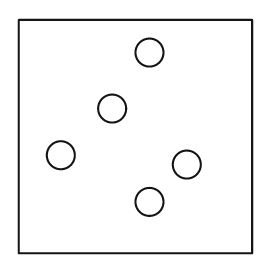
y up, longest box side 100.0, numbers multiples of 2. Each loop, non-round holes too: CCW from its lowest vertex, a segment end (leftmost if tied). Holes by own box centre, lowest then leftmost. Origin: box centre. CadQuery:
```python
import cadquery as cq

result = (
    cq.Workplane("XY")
    .moveTo(-50.0, -50.0)
    .lineTo(50.0, -50.0)
    .lineTo(50.0, 50.0)
    .lineTo(-50.0, 50.0)
    .close()
    .moveTo(6.0, -28.0)
    .circle(6.0)
    .moveTo(22.0, -12.0)
    .circle(6.0)
    .moveTo(-32.0, -8.0)
    .circle(6.0)
    .moveTo(-10.0, 12.0)
    .circle(6.0)
    .moveTo(6.0, 36.0)
    .circle(6.0)
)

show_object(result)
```